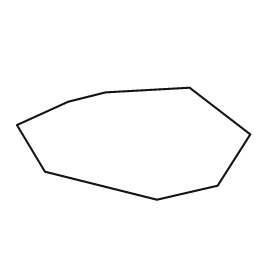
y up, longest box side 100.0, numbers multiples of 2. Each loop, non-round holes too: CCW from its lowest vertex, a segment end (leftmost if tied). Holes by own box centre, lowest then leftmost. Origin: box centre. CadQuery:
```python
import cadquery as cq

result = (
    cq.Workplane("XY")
    .moveTo(10.0, -24.0)
    .lineTo(36.0, -18.0)
    .lineTo(50.0, 4.0)
    .lineTo(24.0, 24.0)
    .lineTo(-12.0, 22.0)
    .lineTo(-28.0, 18.0)
    .lineTo(-50.0, 8.0)
    .lineTo(-38.0, -12.0)
    .close()
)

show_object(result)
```